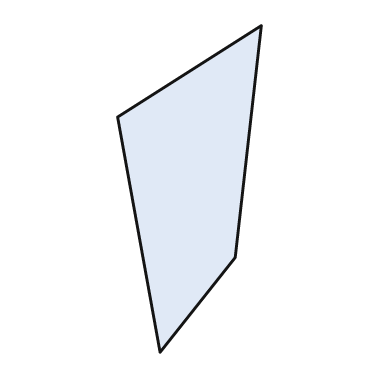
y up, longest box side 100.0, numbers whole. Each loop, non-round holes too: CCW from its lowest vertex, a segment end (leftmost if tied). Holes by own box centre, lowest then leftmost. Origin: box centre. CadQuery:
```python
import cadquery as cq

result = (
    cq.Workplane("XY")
    .moveTo(-9.0, -50.0)
    .lineTo(14.0, -21.0)
    .lineTo(22.0, 50.0)
    .lineTo(-22.0, 22.0)
    .close()
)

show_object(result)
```